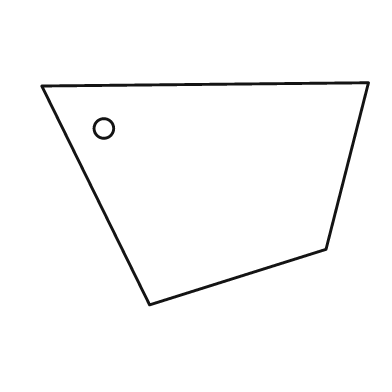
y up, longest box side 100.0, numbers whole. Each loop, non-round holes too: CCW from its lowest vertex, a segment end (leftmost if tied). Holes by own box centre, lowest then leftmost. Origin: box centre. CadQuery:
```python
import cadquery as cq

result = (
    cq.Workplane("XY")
    .moveTo(-17.0, -34.0)
    .lineTo(37.0, -17.0)
    .lineTo(50.0, 34.0)
    .lineTo(-50.0, 33.0)
    .close()
    .moveTo(-31.0, 20.0)
    .circle(3.0)
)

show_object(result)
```